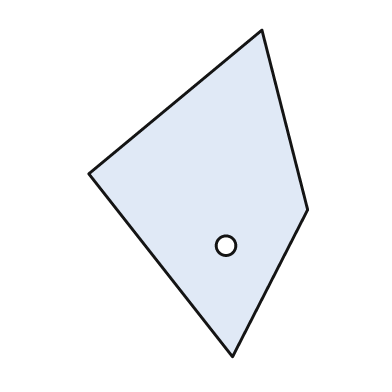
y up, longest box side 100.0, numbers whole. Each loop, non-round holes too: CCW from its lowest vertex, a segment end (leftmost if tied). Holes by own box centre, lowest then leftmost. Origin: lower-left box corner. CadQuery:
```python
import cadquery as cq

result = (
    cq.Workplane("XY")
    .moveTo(44.0, 0.0)
    .lineTo(67.0, 45.0)
    .lineTo(53.0, 100.0)
    .lineTo(0.0, 56.0)
    .close()
    .moveTo(42.0, 34.0)
    .circle(3.0)
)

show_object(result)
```